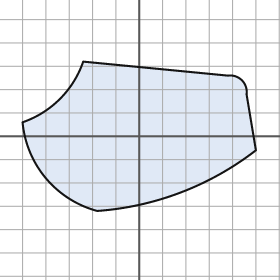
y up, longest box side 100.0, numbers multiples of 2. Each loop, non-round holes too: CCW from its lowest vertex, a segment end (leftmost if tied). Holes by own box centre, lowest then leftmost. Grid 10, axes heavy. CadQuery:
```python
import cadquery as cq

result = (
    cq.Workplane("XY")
    .moveTo(-18.0, -32.0)
    .threePointArc((18.0, -24.0), (50.0, -6.0))
    .lineTo(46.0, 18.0)
    .threePointArc((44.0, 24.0), (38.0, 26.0))
    .lineTo(-24.0, 32.0)
    .threePointArc((-34.0, 16.0), (-50.0, 6.0))
    .threePointArc((-40.0, -18.0), (-18.0, -32.0))
    .close()
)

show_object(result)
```